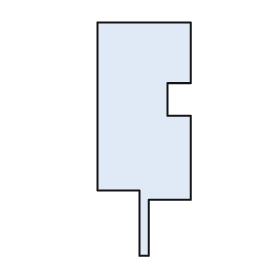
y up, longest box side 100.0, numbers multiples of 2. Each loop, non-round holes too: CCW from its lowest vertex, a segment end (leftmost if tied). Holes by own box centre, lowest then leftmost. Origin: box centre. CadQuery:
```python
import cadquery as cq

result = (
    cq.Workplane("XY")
    .moveTo(-2.0, -50.0)
    .lineTo(2.0, -50.0)
    .lineTo(2.0, -26.0)
    .lineTo(20.0, -26.0)
    .lineTo(20.0, 10.0)
    .lineTo(10.0, 10.0)
    .lineTo(10.0, 24.0)
    .lineTo(20.0, 24.0)
    .lineTo(20.0, 50.0)
    .lineTo(-20.0, 50.0)
    .lineTo(-20.0, -22.0)
    .lineTo(-2.0, -22.0)
    .close()
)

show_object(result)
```